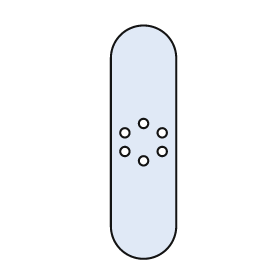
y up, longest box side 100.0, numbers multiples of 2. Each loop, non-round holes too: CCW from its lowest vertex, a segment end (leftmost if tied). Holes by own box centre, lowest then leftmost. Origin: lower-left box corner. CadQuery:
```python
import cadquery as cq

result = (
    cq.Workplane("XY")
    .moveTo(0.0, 14.0)
    .threePointArc((14.0, 0.0), (28.0, 14.0))
    .lineTo(28.0, 86.0)
    .threePointArc((14.0, 100.0), (0.0, 86.0))
    .close()
    .moveTo(14.0, 42.0)
    .circle(2.0)
    .moveTo(6.0, 46.0)
    .circle(2.0)
    .moveTo(22.0, 46.0)
    .circle(2.0)
    .moveTo(6.0, 54.0)
    .circle(2.0)
    .moveTo(22.0, 54.0)
    .circle(2.0)
    .moveTo(14.0, 58.0)
    .circle(2.0)
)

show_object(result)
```